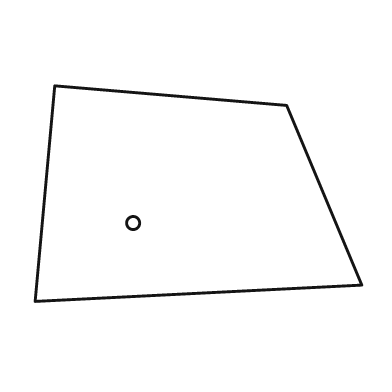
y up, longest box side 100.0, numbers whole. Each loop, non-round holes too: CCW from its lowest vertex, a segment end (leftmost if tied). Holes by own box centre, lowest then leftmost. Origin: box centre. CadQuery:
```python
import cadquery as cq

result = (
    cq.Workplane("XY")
    .moveTo(-50.0, -33.0)
    .lineTo(50.0, -28.0)
    .lineTo(27.0, 27.0)
    .lineTo(-44.0, 33.0)
    .close()
    .moveTo(-20.0, -9.0)
    .circle(2.0)
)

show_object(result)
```